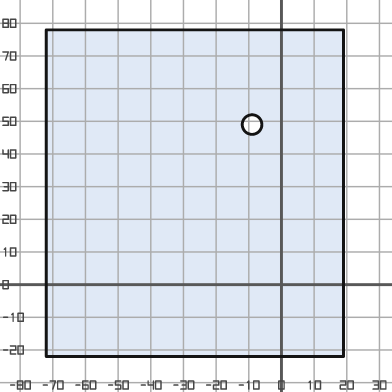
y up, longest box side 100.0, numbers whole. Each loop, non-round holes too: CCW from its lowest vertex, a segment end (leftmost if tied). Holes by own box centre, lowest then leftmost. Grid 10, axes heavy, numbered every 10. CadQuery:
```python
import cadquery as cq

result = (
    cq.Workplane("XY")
    .moveTo(-72.0, -22.0)
    .lineTo(19.0, -22.0)
    .lineTo(19.0, 78.0)
    .lineTo(-72.0, 78.0)
    .close()
    .moveTo(-9.0, 49.0)
    .circle(3.0)
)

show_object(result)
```